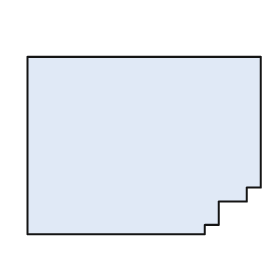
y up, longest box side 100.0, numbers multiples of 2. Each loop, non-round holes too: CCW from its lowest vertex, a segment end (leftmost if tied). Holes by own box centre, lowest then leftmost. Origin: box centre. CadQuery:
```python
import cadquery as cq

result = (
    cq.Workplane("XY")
    .moveTo(-50.0, -38.0)
    .lineTo(26.0, -38.0)
    .lineTo(26.0, -34.0)
    .lineTo(32.0, -34.0)
    .lineTo(32.0, -24.0)
    .lineTo(44.0, -24.0)
    .lineTo(44.0, -18.0)
    .lineTo(50.0, -18.0)
    .lineTo(50.0, 38.0)
    .lineTo(-50.0, 38.0)
    .close()
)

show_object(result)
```